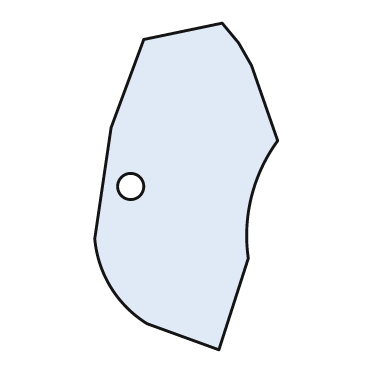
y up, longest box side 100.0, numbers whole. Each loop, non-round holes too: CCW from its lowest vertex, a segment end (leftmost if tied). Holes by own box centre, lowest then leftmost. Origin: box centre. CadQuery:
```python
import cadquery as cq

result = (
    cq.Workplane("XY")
    .moveTo(10.0, -50.0)
    .lineTo(19.0, -22.0)
    .threePointArc((20.0, -3.0), (28.0, 14.0))
    .lineTo(20.0, 37.0)
    .lineTo(16.0, 44.0)
    .lineTo(11.0, 50.0)
    .lineTo(-13.0, 45.0)
    .lineTo(-23.0, 18.0)
    .lineTo(-28.0, -16.0)
    .threePointArc((-23.0, -31.0), (-12.0, -42.0))
    .close()
    .moveTo(-17.0, 0.0)
    .circle(4.0)
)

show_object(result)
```